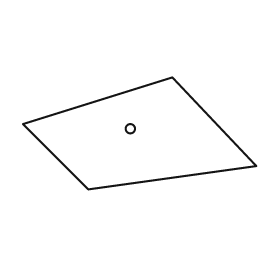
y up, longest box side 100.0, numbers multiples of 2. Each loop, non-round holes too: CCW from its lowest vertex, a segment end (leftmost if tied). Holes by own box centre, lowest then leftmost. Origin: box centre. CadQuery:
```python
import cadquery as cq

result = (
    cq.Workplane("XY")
    .moveTo(-22.0, -24.0)
    .lineTo(50.0, -14.0)
    .lineTo(14.0, 24.0)
    .lineTo(-50.0, 4.0)
    .close()
    .moveTo(-4.0, 2.0)
    .circle(2.0)
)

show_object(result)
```